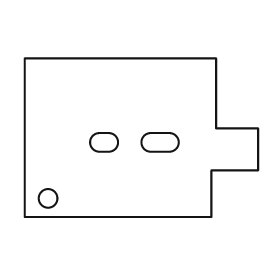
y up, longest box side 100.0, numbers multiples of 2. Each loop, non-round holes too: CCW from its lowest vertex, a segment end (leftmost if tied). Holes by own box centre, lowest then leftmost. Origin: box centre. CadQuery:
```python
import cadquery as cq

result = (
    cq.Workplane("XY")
    .moveTo(-50.0, -34.0)
    .lineTo(30.0, -34.0)
    .lineTo(30.0, -14.0)
    .lineTo(50.0, -14.0)
    .lineTo(50.0, 4.0)
    .lineTo(32.0, 4.0)
    .lineTo(32.0, 34.0)
    .lineTo(-50.0, 34.0)
    .close()
    .moveTo(-40.0, -26.0)
    .circle(4.0)
    .moveTo(-18.0, -6.0)
    .lineTo(-14.0, -6.0)
    .threePointArc((-10.0, -2.0), (-14.0, 2.0))
    .lineTo(-18.0, 2.0)
    .threePointArc((-22.0, -2.0), (-18.0, -6.0))
    .close()
    .moveTo(4.0, -6.0)
    .lineTo(12.0, -6.0)
    .threePointArc((16.0, -2.0), (12.0, 2.0))
    .lineTo(4.0, 2.0)
    .threePointArc((0.0, -2.0), (4.0, -6.0))
    .close()
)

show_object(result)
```